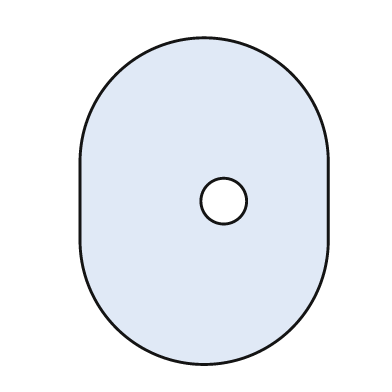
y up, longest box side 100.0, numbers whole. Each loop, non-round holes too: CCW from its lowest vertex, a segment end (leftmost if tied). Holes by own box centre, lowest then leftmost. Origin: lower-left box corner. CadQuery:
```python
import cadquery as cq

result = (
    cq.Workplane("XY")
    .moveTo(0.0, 38.0)
    .threePointArc((38.0, 0.0), (76.0, 38.0))
    .lineTo(76.0, 62.0)
    .threePointArc((38.0, 100.0), (0.0, 62.0))
    .close()
    .moveTo(44.0, 50.0)
    .circle(7.0)
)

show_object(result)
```